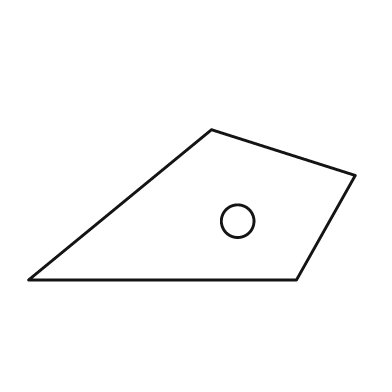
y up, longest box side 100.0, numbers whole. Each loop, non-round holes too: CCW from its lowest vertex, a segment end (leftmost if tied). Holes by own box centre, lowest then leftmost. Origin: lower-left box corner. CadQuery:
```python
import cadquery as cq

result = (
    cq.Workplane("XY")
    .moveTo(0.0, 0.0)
    .lineTo(82.0, 0.0)
    .lineTo(100.0, 32.0)
    .lineTo(56.0, 46.0)
    .close()
    .moveTo(64.0, 18.0)
    .circle(5.0)
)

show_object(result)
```